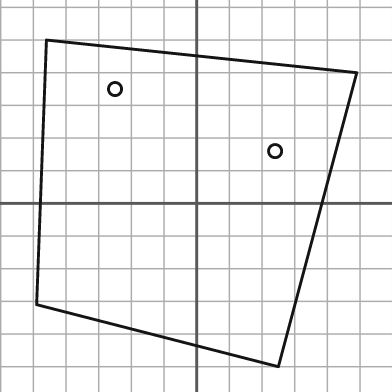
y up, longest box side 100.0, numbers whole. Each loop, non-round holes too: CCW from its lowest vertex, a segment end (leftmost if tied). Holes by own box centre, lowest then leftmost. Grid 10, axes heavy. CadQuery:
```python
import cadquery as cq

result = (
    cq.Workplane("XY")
    .moveTo(25.0, -50.0)
    .lineTo(49.0, 40.0)
    .lineTo(-46.0, 50.0)
    .lineTo(-49.0, -31.0)
    .close()
    .moveTo(24.0, 16.0)
    .circle(2.0)
    .moveTo(-25.0, 35.0)
    .circle(2.0)
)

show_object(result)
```